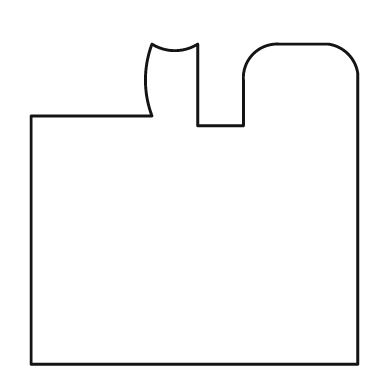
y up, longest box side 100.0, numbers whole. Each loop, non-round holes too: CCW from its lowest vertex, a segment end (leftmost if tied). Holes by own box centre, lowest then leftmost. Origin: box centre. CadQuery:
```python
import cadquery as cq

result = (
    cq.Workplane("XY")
    .moveTo(-50.0, -49.0)
    .lineTo(50.0, -49.0)
    .lineTo(50.0, 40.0)
    .threePointArc((47.0, 46.0), (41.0, 49.0))
    .lineTo(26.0, 49.0)
    .threePointArc((18.0, 46.0), (15.0, 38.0))
    .lineTo(15.0, 24.0)
    .lineTo(1.0, 24.0)
    .lineTo(1.0, 49.0)
    .threePointArc((-6.0, 47.0), (-13.0, 49.0))
    .threePointArc((-15.0, 38.0), (-13.0, 27.0))
    .lineTo(-50.0, 27.0)
    .close()
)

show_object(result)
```